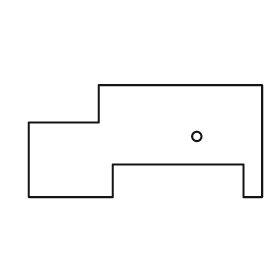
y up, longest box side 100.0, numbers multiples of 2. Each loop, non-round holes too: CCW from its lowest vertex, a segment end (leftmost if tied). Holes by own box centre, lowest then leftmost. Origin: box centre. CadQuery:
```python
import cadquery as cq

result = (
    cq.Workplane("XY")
    .moveTo(-50.0, -24.0)
    .lineTo(-14.0, -24.0)
    .lineTo(-14.0, -10.0)
    .lineTo(42.0, -10.0)
    .lineTo(42.0, -24.0)
    .lineTo(50.0, -24.0)
    .lineTo(50.0, 24.0)
    .lineTo(-20.0, 24.0)
    .lineTo(-20.0, 8.0)
    .lineTo(-50.0, 8.0)
    .close()
    .moveTo(22.0, 2.0)
    .circle(2.0)
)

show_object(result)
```